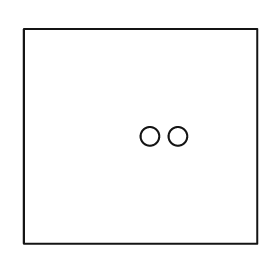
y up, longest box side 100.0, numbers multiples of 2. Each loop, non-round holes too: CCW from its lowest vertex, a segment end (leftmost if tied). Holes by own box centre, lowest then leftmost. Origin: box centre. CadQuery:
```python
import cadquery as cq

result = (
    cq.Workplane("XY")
    .moveTo(-50.0, -46.0)
    .lineTo(50.0, -46.0)
    .lineTo(50.0, 46.0)
    .lineTo(-50.0, 46.0)
    .close()
    .moveTo(4.0, 0.0)
    .circle(4.0)
    .moveTo(16.0, 0.0)
    .circle(4.0)
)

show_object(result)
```